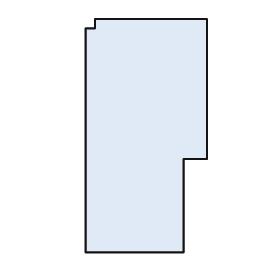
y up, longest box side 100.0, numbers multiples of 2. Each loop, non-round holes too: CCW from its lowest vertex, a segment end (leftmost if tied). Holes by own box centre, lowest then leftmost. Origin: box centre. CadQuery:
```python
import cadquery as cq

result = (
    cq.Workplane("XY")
    .moveTo(-26.0, -50.0)
    .lineTo(16.0, -50.0)
    .lineTo(16.0, -10.0)
    .lineTo(26.0, -10.0)
    .lineTo(26.0, 50.0)
    .lineTo(-22.0, 50.0)
    .lineTo(-22.0, 46.0)
    .lineTo(-26.0, 46.0)
    .close()
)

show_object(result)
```